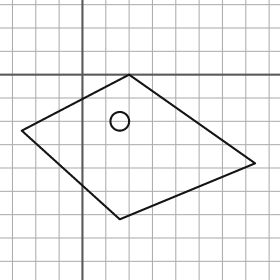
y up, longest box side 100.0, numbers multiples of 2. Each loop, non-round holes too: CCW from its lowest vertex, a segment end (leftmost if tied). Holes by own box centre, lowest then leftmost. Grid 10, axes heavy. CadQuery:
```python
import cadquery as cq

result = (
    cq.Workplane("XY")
    .moveTo(16.0, -62.0)
    .lineTo(74.0, -38.0)
    .lineTo(20.0, 0.0)
    .lineTo(-26.0, -24.0)
    .close()
    .moveTo(16.0, -20.0)
    .circle(4.0)
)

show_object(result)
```